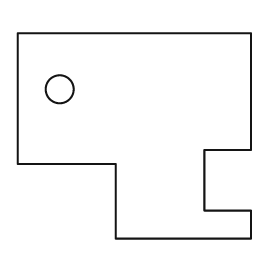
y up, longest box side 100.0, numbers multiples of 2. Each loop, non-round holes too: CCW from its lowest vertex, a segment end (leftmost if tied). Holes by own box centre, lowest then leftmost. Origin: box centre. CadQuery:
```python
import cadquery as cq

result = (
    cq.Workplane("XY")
    .moveTo(-8.0, -44.0)
    .lineTo(50.0, -44.0)
    .lineTo(50.0, -32.0)
    .lineTo(30.0, -32.0)
    .lineTo(30.0, -6.0)
    .lineTo(50.0, -6.0)
    .lineTo(50.0, 44.0)
    .lineTo(-50.0, 44.0)
    .lineTo(-50.0, -12.0)
    .lineTo(-8.0, -12.0)
    .close()
    .moveTo(-32.0, 20.0)
    .circle(6.0)
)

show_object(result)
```